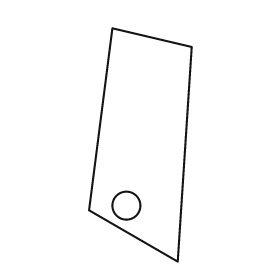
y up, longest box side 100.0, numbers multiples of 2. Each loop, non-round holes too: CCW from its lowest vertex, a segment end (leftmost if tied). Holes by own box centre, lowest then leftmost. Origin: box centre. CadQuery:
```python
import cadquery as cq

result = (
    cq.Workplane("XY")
    .moveTo(16.0, -50.0)
    .lineTo(22.0, 42.0)
    .lineTo(-12.0, 50.0)
    .lineTo(-22.0, -28.0)
    .close()
    .moveTo(-6.0, -26.0)
    .circle(6.0)
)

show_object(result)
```